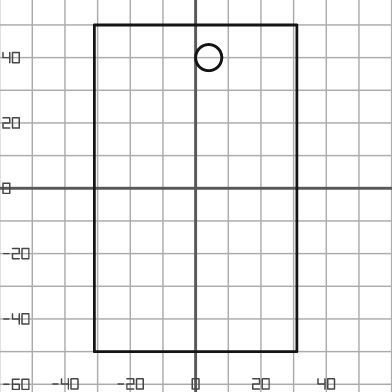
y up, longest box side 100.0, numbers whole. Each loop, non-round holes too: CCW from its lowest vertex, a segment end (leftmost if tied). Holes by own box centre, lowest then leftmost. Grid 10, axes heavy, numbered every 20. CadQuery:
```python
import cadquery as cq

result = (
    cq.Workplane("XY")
    .moveTo(-31.0, -50.0)
    .lineTo(31.0, -50.0)
    .lineTo(31.0, 50.0)
    .lineTo(-31.0, 50.0)
    .close()
    .moveTo(4.0, 40.0)
    .circle(4.0)
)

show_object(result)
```